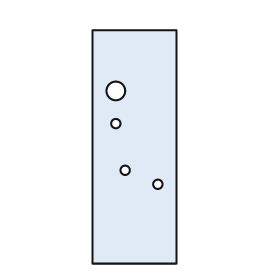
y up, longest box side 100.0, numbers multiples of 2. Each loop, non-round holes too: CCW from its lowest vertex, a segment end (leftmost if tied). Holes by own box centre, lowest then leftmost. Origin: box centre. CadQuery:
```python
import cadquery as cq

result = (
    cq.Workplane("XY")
    .moveTo(-18.0, -50.0)
    .lineTo(18.0, -50.0)
    .lineTo(18.0, 50.0)
    .lineTo(-18.0, 50.0)
    .close()
    .moveTo(10.0, -16.0)
    .circle(2.0)
    .moveTo(-4.0, -10.0)
    .circle(2.0)
    .moveTo(-8.0, 10.0)
    .circle(2.0)
    .moveTo(-8.0, 24.0)
    .circle(4.0)
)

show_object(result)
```